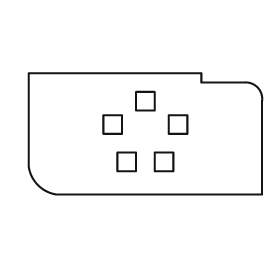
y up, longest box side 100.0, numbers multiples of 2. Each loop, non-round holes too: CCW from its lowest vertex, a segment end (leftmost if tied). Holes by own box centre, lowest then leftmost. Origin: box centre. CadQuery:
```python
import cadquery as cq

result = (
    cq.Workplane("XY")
    .moveTo(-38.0, -26.0)
    .lineTo(50.0, -26.0)
    .lineTo(50.0, 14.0)
    .threePointArc((48.0, 20.0), (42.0, 22.0))
    .lineTo(24.0, 22.0)
    .lineTo(24.0, 26.0)
    .lineTo(-50.0, 26.0)
    .lineTo(-50.0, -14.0)
    .threePointArc((-46.0, -22.0), (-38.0, -26.0))
    .close()
    .moveTo(-12.0, -16.0)
    .lineTo(-4.0, -16.0)
    .lineTo(-4.0, -8.0)
    .lineTo(-12.0, -8.0)
    .close()
    .moveTo(4.0, -16.0)
    .lineTo(12.0, -16.0)
    .lineTo(12.0, -8.0)
    .lineTo(4.0, -8.0)
    .close()
    .moveTo(-18.0, 0.0)
    .lineTo(-10.0, 0.0)
    .lineTo(-10.0, 8.0)
    .lineTo(-18.0, 8.0)
    .close()
    .moveTo(10.0, 0.0)
    .lineTo(18.0, 0.0)
    .lineTo(18.0, 8.0)
    .lineTo(10.0, 8.0)
    .close()
    .moveTo(-4.0, 10.0)
    .lineTo(4.0, 10.0)
    .lineTo(4.0, 18.0)
    .lineTo(-4.0, 18.0)
    .close()
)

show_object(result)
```